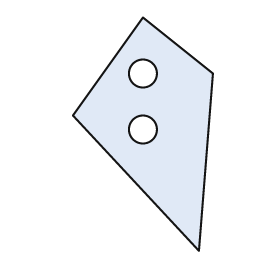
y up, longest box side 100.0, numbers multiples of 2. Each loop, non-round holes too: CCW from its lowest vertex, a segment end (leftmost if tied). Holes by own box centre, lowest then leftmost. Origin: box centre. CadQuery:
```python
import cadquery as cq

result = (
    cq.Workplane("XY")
    .moveTo(24.0, -50.0)
    .lineTo(30.0, 26.0)
    .lineTo(0.0, 50.0)
    .lineTo(-30.0, 8.0)
    .close()
    .moveTo(0.0, 2.0)
    .circle(6.0)
    .moveTo(0.0, 26.0)
    .circle(6.0)
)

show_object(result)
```